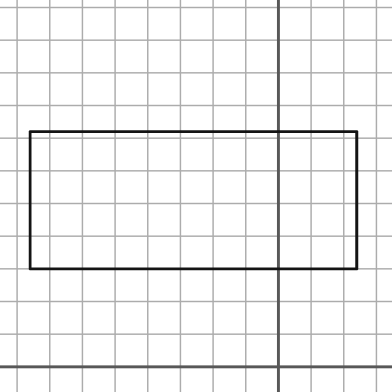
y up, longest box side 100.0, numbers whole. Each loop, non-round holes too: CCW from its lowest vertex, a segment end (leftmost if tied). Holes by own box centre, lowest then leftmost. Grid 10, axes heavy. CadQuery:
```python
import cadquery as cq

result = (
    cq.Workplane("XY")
    .moveTo(-76.0, 30.0)
    .lineTo(24.0, 30.0)
    .lineTo(24.0, 72.0)
    .lineTo(-76.0, 72.0)
    .close()
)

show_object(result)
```